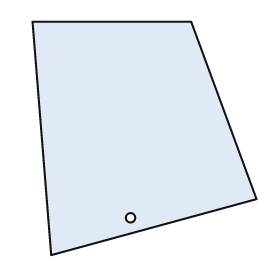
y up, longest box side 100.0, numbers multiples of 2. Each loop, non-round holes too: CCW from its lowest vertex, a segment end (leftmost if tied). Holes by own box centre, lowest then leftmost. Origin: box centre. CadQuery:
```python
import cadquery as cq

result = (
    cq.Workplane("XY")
    .moveTo(-40.0, -50.0)
    .lineTo(48.0, -26.0)
    .lineTo(20.0, 50.0)
    .lineTo(-48.0, 50.0)
    .close()
    .moveTo(-6.0, -34.0)
    .circle(2.0)
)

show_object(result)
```